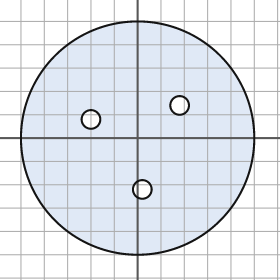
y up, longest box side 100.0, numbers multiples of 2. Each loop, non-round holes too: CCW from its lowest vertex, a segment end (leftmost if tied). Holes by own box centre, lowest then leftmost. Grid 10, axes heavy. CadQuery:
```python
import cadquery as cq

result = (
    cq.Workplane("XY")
    .moveTo(0.0, 0.0)
    .circle(50.0)
    .moveTo(2.0, -22.0)
    .circle(4.0)
    .moveTo(-20.0, 8.0)
    .circle(4.0)
    .moveTo(18.0, 14.0)
    .circle(4.0)
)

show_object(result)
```